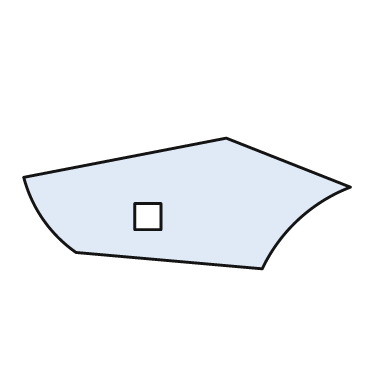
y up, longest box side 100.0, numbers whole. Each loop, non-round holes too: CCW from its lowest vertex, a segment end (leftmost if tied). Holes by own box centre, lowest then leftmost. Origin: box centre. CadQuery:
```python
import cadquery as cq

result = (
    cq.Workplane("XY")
    .moveTo(23.0, -20.0)
    .threePointArc((34.0, -5.0), (50.0, 5.0))
    .lineTo(12.0, 20.0)
    .lineTo(-50.0, 8.0)
    .threePointArc((-44.0, -5.0), (-34.0, -15.0))
    .close()
    .moveTo(-16.0, -8.0)
    .lineTo(-8.0, -8.0)
    .lineTo(-8.0, 0.0)
    .lineTo(-16.0, 0.0)
    .close()
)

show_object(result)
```